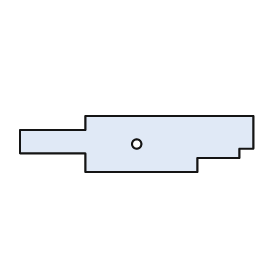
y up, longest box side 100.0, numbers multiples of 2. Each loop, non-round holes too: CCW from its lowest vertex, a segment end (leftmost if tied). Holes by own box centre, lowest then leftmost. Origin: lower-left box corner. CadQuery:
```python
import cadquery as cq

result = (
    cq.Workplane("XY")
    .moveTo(28.0, 0.0)
    .lineTo(76.0, 0.0)
    .lineTo(76.0, 6.0)
    .lineTo(94.0, 6.0)
    .lineTo(94.0, 10.0)
    .lineTo(100.0, 10.0)
    .lineTo(100.0, 24.0)
    .lineTo(28.0, 24.0)
    .lineTo(28.0, 18.0)
    .lineTo(0.0, 18.0)
    .lineTo(0.0, 8.0)
    .lineTo(28.0, 8.0)
    .close()
    .moveTo(50.0, 12.0)
    .circle(2.0)
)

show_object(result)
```